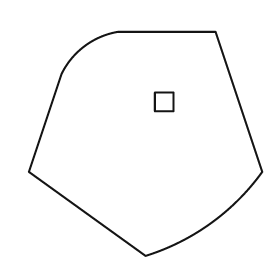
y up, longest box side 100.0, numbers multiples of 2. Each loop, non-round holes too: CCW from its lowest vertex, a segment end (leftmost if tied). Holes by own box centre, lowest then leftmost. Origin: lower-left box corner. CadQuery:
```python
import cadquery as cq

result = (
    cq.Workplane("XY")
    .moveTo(50.0, 0.0)
    .threePointArc((78.0, 14.0), (100.0, 36.0))
    .lineTo(80.0, 96.0)
    .lineTo(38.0, 96.0)
    .threePointArc((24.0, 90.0), (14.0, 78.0))
    .lineTo(0.0, 36.0)
    .close()
    .moveTo(54.0, 62.0)
    .lineTo(62.0, 62.0)
    .lineTo(62.0, 70.0)
    .lineTo(54.0, 70.0)
    .close()
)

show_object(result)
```